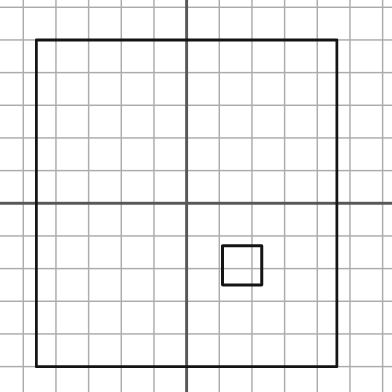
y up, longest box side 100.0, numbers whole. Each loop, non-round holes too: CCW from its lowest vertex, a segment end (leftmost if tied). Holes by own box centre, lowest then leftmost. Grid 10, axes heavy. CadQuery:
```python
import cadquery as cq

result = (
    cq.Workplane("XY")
    .moveTo(-46.0, -50.0)
    .lineTo(46.0, -50.0)
    .lineTo(46.0, 50.0)
    .lineTo(-46.0, 50.0)
    .close()
    .moveTo(11.0, -25.0)
    .lineTo(23.0, -25.0)
    .lineTo(23.0, -13.0)
    .lineTo(11.0, -13.0)
    .close()
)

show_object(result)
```